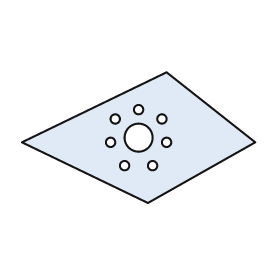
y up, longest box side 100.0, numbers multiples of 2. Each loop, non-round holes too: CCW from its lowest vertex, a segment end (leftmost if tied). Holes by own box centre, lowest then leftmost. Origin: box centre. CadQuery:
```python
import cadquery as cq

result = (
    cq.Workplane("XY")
    .moveTo(4.0, -28.0)
    .lineTo(50.0, -2.0)
    .lineTo(12.0, 28.0)
    .lineTo(-50.0, -2.0)
    .close()
    .moveTo(-6.0, -12.0)
    .circle(2.0)
    .moveTo(6.0, -12.0)
    .circle(2.0)
    .moveTo(-12.0, -2.0)
    .circle(2.0)
    .moveTo(12.0, -2.0)
    .circle(2.0)
    .moveTo(0.0, 0.0)
    .circle(6.0)
    .moveTo(-10.0, 8.0)
    .circle(2.0)
    .moveTo(10.0, 8.0)
    .circle(2.0)
    .moveTo(0.0, 12.0)
    .circle(2.0)
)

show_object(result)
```